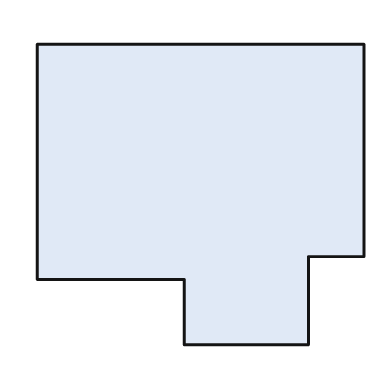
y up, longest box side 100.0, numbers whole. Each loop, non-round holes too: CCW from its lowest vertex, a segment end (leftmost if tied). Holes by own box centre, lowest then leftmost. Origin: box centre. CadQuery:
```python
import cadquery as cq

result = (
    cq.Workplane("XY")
    .moveTo(-5.0, -46.0)
    .lineTo(33.0, -46.0)
    .lineTo(33.0, -19.0)
    .lineTo(50.0, -19.0)
    .lineTo(50.0, 46.0)
    .lineTo(-50.0, 46.0)
    .lineTo(-50.0, -26.0)
    .lineTo(-5.0, -26.0)
    .close()
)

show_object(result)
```